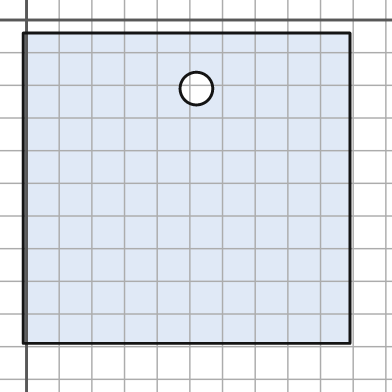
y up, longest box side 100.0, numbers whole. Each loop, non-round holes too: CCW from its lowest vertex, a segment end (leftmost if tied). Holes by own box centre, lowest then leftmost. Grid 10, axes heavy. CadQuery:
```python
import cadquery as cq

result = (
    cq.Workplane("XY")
    .moveTo(-1.0, -99.0)
    .lineTo(99.0, -99.0)
    .lineTo(99.0, -4.0)
    .lineTo(-1.0, -4.0)
    .close()
    .moveTo(52.0, -21.0)
    .circle(5.0)
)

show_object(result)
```